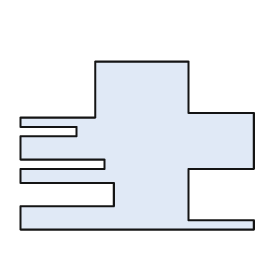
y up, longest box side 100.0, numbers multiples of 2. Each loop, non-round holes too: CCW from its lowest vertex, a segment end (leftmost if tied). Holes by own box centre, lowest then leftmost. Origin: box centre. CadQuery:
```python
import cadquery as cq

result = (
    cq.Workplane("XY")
    .moveTo(-50.0, -36.0)
    .lineTo(50.0, -36.0)
    .lineTo(50.0, -32.0)
    .lineTo(22.0, -32.0)
    .lineTo(22.0, -10.0)
    .lineTo(50.0, -10.0)
    .lineTo(50.0, 14.0)
    .lineTo(22.0, 14.0)
    .lineTo(22.0, 36.0)
    .lineTo(-18.0, 36.0)
    .lineTo(-18.0, 12.0)
    .lineTo(-50.0, 12.0)
    .lineTo(-50.0, 8.0)
    .lineTo(-26.0, 8.0)
    .lineTo(-26.0, 4.0)
    .lineTo(-50.0, 4.0)
    .lineTo(-50.0, -6.0)
    .lineTo(-14.0, -6.0)
    .lineTo(-14.0, -10.0)
    .lineTo(-50.0, -10.0)
    .lineTo(-50.0, -16.0)
    .lineTo(-10.0, -16.0)
    .lineTo(-10.0, -26.0)
    .lineTo(-50.0, -26.0)
    .close()
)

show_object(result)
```